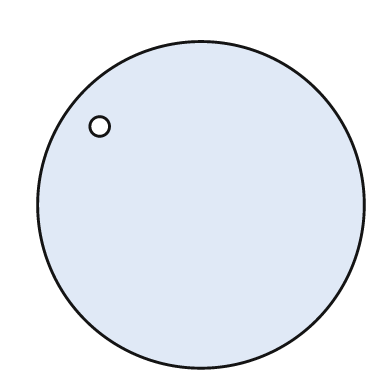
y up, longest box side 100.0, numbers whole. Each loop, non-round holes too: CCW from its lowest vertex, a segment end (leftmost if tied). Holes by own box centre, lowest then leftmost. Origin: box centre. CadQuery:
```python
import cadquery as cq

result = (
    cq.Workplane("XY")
    .moveTo(0.0, 0.0)
    .circle(50.0)
    .moveTo(-31.0, 24.0)
    .circle(3.0)
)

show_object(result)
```